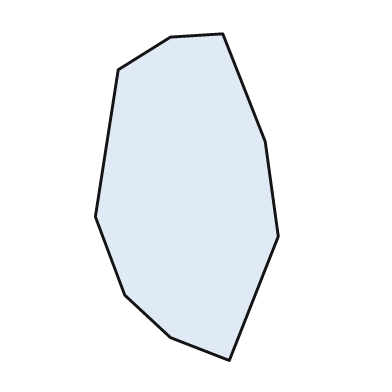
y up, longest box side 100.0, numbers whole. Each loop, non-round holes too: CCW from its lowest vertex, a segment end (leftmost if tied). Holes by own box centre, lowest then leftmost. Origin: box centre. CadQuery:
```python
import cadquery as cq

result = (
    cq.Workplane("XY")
    .moveTo(13.0, -50.0)
    .lineTo(28.0, -12.0)
    .lineTo(24.0, 17.0)
    .lineTo(11.0, 50.0)
    .lineTo(-5.0, 49.0)
    .lineTo(-21.0, 39.0)
    .lineTo(-28.0, -6.0)
    .lineTo(-19.0, -30.0)
    .lineTo(-5.0, -43.0)
    .close()
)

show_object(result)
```